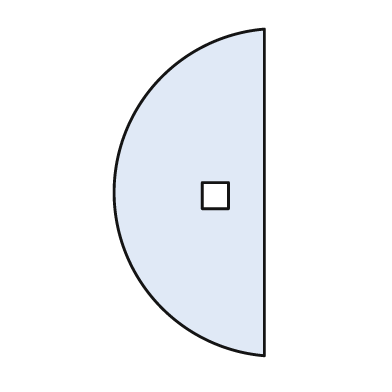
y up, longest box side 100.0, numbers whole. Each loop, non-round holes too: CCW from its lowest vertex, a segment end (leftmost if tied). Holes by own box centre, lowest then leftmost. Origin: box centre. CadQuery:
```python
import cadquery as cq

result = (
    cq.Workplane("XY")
    .moveTo(23.0, -50.0)
    .lineTo(23.0, 50.0)
    .threePointArc((-23.0, 0.0), (23.0, -50.0))
    .close()
    .moveTo(4.0, -5.0)
    .lineTo(12.0, -5.0)
    .lineTo(12.0, 3.0)
    .lineTo(4.0, 3.0)
    .close()
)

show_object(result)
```